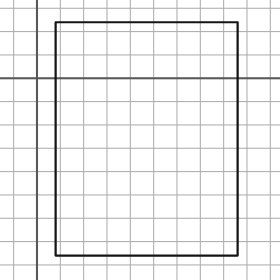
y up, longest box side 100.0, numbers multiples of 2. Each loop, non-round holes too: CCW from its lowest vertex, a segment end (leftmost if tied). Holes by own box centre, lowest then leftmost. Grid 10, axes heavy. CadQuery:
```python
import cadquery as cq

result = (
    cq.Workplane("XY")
    .moveTo(8.0, -76.0)
    .lineTo(86.0, -76.0)
    .lineTo(86.0, 24.0)
    .lineTo(8.0, 24.0)
    .close()
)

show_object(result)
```